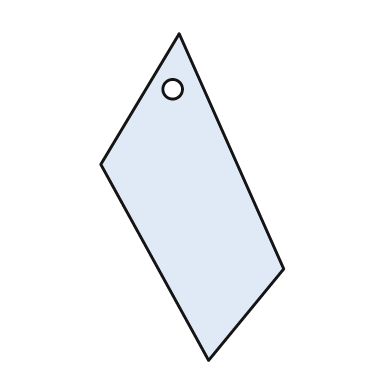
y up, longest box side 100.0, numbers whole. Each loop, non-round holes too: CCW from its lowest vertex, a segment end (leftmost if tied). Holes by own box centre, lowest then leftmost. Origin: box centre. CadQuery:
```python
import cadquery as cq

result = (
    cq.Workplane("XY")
    .moveTo(5.0, -50.0)
    .lineTo(28.0, -22.0)
    .lineTo(-4.0, 50.0)
    .lineTo(-28.0, 10.0)
    .close()
    .moveTo(-6.0, 33.0)
    .circle(3.0)
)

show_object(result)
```